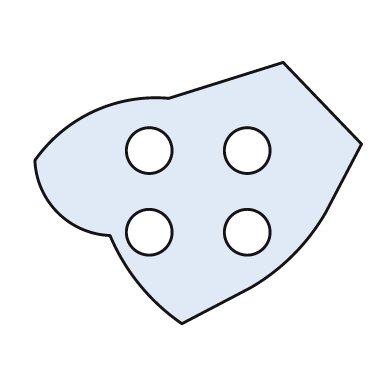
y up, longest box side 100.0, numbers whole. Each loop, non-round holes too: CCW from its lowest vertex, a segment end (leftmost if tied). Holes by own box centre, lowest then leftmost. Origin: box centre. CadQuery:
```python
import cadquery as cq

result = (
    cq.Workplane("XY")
    .moveTo(-5.0, -40.0)
    .lineTo(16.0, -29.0)
    .threePointArc((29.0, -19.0), (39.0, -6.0))
    .lineTo(50.0, 15.0)
    .lineTo(26.0, 40.0)
    .lineTo(-9.0, 29.0)
    .threePointArc((-32.0, 25.0), (-50.0, 10.0))
    .threePointArc((-43.0, -6.0), (-27.0, -13.0))
    .threePointArc((-18.0, -28.0), (-5.0, -40.0))
    .close()
    .moveTo(-15.0, -12.0)
    .circle(7.0)
    .moveTo(15.0, -12.0)
    .circle(7.0)
    .moveTo(-15.0, 13.0)
    .circle(7.0)
    .moveTo(15.0, 13.0)
    .circle(7.0)
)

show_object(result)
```